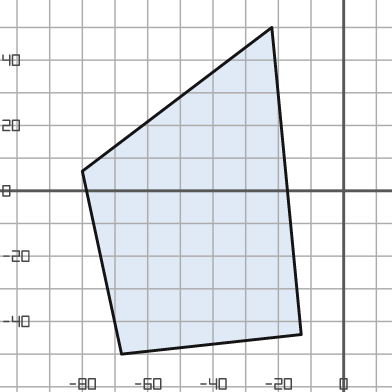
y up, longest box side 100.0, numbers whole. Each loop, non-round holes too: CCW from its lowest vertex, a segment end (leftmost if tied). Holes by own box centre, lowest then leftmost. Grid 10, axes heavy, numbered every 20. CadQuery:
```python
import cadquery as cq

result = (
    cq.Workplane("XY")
    .moveTo(-68.0, -50.0)
    .lineTo(-13.0, -44.0)
    .lineTo(-22.0, 50.0)
    .lineTo(-80.0, 6.0)
    .close()
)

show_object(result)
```